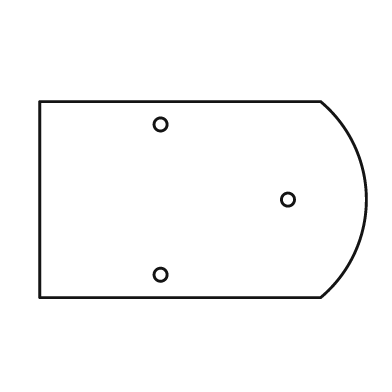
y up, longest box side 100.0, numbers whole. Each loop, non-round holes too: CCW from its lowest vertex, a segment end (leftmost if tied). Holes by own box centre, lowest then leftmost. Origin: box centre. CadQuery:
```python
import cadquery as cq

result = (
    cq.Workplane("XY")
    .moveTo(-50.0, -30.0)
    .lineTo(36.0, -30.0)
    .threePointArc((50.0, 0.0), (36.0, 30.0))
    .lineTo(-50.0, 30.0)
    .close()
    .moveTo(-13.0, -23.0)
    .circle(2.0)
    .moveTo(26.0, 0.0)
    .circle(2.0)
    .moveTo(-13.0, 23.0)
    .circle(2.0)
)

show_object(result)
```